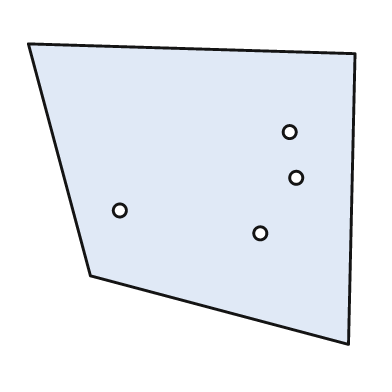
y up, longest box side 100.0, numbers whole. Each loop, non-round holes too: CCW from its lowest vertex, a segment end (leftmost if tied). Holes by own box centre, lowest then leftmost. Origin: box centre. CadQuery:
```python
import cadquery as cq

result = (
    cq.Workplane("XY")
    .moveTo(48.0, -46.0)
    .lineTo(50.0, 43.0)
    .lineTo(-50.0, 46.0)
    .lineTo(-31.0, -25.0)
    .close()
    .moveTo(21.0, -12.0)
    .circle(2.0)
    .moveTo(-22.0, -5.0)
    .circle(2.0)
    .moveTo(32.0, 5.0)
    .circle(2.0)
    .moveTo(30.0, 19.0)
    .circle(2.0)
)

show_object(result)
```